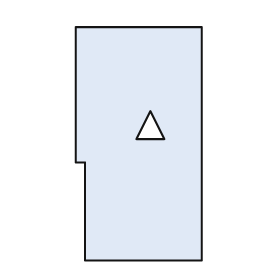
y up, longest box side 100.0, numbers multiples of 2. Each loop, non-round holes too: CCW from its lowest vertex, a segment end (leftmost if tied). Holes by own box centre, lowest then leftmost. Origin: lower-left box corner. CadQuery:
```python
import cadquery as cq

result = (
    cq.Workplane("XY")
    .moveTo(4.0, 0.0)
    .lineTo(54.0, 0.0)
    .lineTo(54.0, 100.0)
    .lineTo(0.0, 100.0)
    .lineTo(0.0, 42.0)
    .lineTo(4.0, 42.0)
    .close()
    .moveTo(26.0, 52.0)
    .lineTo(38.0, 52.0)
    .lineTo(32.0, 64.0)
    .close()
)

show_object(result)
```